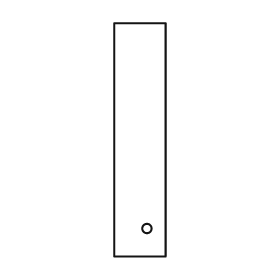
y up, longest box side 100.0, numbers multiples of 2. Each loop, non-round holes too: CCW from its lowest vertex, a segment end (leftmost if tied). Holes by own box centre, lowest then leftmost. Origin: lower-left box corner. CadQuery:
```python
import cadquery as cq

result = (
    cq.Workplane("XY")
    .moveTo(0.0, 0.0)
    .lineTo(22.0, 0.0)
    .lineTo(22.0, 100.0)
    .lineTo(0.0, 100.0)
    .close()
    .moveTo(14.0, 12.0)
    .circle(2.0)
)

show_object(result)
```